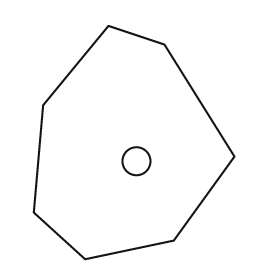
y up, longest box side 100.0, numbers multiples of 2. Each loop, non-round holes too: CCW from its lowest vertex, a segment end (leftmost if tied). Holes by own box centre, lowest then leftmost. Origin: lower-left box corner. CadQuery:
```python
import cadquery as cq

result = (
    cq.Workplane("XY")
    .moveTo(22.0, 0.0)
    .lineTo(60.0, 8.0)
    .lineTo(86.0, 44.0)
    .lineTo(56.0, 92.0)
    .lineTo(32.0, 100.0)
    .lineTo(4.0, 66.0)
    .lineTo(0.0, 20.0)
    .close()
    .moveTo(44.0, 42.0)
    .circle(6.0)
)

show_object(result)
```